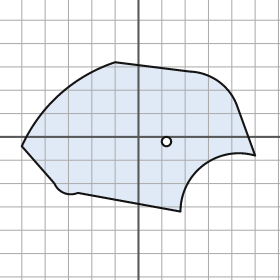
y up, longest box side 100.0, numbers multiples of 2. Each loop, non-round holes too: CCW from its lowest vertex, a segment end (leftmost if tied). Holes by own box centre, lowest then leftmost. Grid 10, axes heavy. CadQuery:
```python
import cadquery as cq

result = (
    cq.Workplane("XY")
    .moveTo(18.0, -32.0)
    .threePointArc((28.0, -12.0), (50.0, -8.0))
    .lineTo(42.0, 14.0)
    .threePointArc((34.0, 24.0), (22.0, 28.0))
    .lineTo(-10.0, 32.0)
    .threePointArc((-34.0, 18.0), (-50.0, -4.0))
    .lineTo(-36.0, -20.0)
    .threePointArc((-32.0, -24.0), (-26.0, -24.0))
    .close()
    .moveTo(12.0, -2.0)
    .circle(2.0)
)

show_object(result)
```